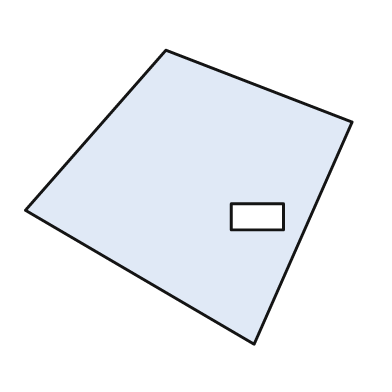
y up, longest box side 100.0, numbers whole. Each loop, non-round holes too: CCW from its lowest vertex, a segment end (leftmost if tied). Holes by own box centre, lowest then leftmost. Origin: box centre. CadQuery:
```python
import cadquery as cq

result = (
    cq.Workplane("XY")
    .moveTo(20.0, -45.0)
    .lineTo(50.0, 23.0)
    .lineTo(-7.0, 45.0)
    .lineTo(-50.0, -4.0)
    .close()
    .moveTo(13.0, -10.0)
    .lineTo(29.0, -10.0)
    .lineTo(29.0, -2.0)
    .lineTo(13.0, -2.0)
    .close()
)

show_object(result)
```